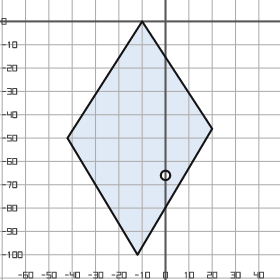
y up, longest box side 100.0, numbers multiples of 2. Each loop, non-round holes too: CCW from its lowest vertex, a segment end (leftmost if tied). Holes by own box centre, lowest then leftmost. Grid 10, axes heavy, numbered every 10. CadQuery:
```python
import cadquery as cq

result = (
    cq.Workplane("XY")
    .moveTo(-12.0, -100.0)
    .lineTo(20.0, -46.0)
    .lineTo(-10.0, 0.0)
    .lineTo(-42.0, -50.0)
    .close()
    .moveTo(0.0, -66.0)
    .circle(2.0)
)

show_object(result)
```